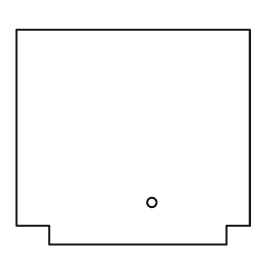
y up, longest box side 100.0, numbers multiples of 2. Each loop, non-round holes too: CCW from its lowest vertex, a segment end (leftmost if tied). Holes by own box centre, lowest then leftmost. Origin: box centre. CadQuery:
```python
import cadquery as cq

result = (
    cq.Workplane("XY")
    .moveTo(-36.0, -46.0)
    .lineTo(40.0, -46.0)
    .lineTo(40.0, -38.0)
    .lineTo(50.0, -38.0)
    .lineTo(50.0, 46.0)
    .lineTo(-50.0, 46.0)
    .lineTo(-50.0, -38.0)
    .lineTo(-36.0, -38.0)
    .close()
    .moveTo(8.0, -28.0)
    .circle(2.0)
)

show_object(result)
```